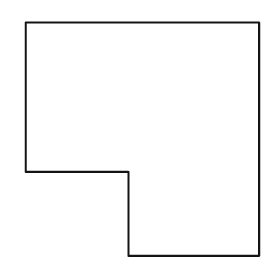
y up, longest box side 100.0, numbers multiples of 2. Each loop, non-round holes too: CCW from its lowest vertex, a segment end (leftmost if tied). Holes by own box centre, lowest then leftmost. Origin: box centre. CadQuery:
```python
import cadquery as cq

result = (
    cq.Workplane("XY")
    .moveTo(-6.0, -50.0)
    .lineTo(50.0, -50.0)
    .lineTo(50.0, 50.0)
    .lineTo(-50.0, 50.0)
    .lineTo(-50.0, -14.0)
    .lineTo(-6.0, -14.0)
    .close()
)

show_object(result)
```